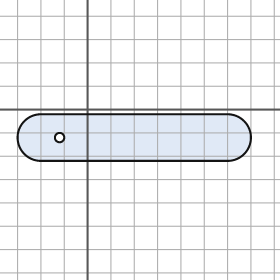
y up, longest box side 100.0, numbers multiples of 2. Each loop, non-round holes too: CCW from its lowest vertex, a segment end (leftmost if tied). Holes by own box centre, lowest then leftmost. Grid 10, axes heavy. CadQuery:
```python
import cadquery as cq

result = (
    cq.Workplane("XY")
    .moveTo(-20.0, -22.0)
    .lineTo(60.0, -22.0)
    .threePointArc((70.0, -12.0), (60.0, -2.0))
    .lineTo(-20.0, -2.0)
    .threePointArc((-30.0, -12.0), (-20.0, -22.0))
    .close()
    .moveTo(-12.0, -12.0)
    .circle(2.0)
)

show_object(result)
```